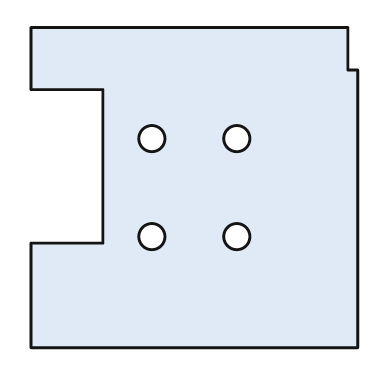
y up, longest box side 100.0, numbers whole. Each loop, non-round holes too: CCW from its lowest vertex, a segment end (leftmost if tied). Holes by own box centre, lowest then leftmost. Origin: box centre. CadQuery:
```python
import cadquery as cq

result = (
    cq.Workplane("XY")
    .moveTo(-50.0, -49.0)
    .lineTo(50.0, -49.0)
    .lineTo(50.0, 36.0)
    .lineTo(47.0, 36.0)
    .lineTo(47.0, 49.0)
    .lineTo(-50.0, 49.0)
    .lineTo(-50.0, 30.0)
    .lineTo(-28.0, 30.0)
    .lineTo(-28.0, -17.0)
    .lineTo(-50.0, -17.0)
    .close()
    .moveTo(-13.0, -15.0)
    .circle(4.0)
    .moveTo(13.0, -15.0)
    .circle(4.0)
    .moveTo(-13.0, 15.0)
    .circle(4.0)
    .moveTo(13.0, 15.0)
    .circle(4.0)
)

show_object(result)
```